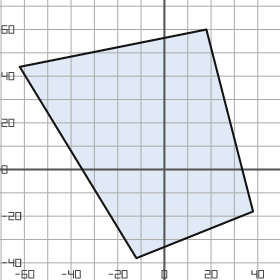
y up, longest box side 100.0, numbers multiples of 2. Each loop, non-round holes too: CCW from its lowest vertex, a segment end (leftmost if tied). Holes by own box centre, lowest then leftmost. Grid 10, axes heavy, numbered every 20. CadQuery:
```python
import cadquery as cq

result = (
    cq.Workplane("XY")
    .moveTo(-12.0, -38.0)
    .lineTo(38.0, -18.0)
    .lineTo(18.0, 60.0)
    .lineTo(-62.0, 44.0)
    .close()
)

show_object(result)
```